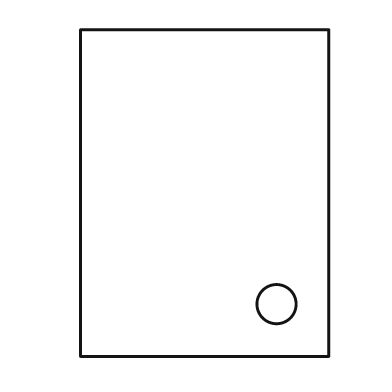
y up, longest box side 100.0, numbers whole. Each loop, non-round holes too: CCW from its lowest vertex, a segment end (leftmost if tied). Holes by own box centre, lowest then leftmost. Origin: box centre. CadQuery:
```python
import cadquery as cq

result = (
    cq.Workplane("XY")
    .moveTo(-38.0, -50.0)
    .lineTo(38.0, -50.0)
    .lineTo(38.0, 50.0)
    .lineTo(-38.0, 50.0)
    .close()
    .moveTo(22.0, -34.0)
    .circle(6.0)
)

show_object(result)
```